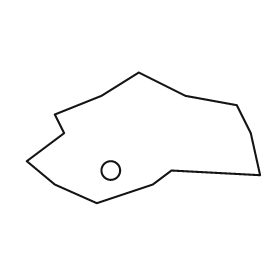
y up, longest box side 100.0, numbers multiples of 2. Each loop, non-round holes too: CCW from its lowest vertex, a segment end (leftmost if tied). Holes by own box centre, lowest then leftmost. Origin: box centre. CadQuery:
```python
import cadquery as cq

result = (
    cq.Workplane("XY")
    .moveTo(-20.0, -28.0)
    .lineTo(4.0, -20.0)
    .lineTo(12.0, -14.0)
    .lineTo(50.0, -16.0)
    .lineTo(46.0, 2.0)
    .lineTo(40.0, 14.0)
    .lineTo(18.0, 18.0)
    .lineTo(-2.0, 28.0)
    .lineTo(-18.0, 18.0)
    .lineTo(-38.0, 10.0)
    .lineTo(-34.0, 2.0)
    .lineTo(-50.0, -10.0)
    .lineTo(-38.0, -20.0)
    .close()
    .moveTo(-14.0, -14.0)
    .circle(4.0)
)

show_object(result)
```